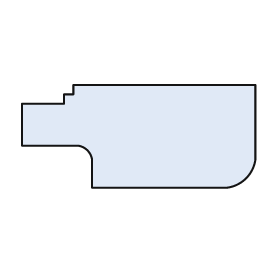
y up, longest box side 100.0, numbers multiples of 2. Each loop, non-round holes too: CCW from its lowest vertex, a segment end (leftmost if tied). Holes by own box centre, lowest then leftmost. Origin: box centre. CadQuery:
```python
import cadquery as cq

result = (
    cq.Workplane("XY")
    .moveTo(-20.0, -22.0)
    .lineTo(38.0, -22.0)
    .threePointArc((46.0, -18.0), (50.0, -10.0))
    .lineTo(50.0, 22.0)
    .lineTo(-28.0, 22.0)
    .lineTo(-28.0, 18.0)
    .lineTo(-32.0, 18.0)
    .lineTo(-32.0, 14.0)
    .lineTo(-50.0, 14.0)
    .lineTo(-50.0, -4.0)
    .lineTo(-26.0, -4.0)
    .threePointArc((-22.0, -6.0), (-20.0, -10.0))
    .close()
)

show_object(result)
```